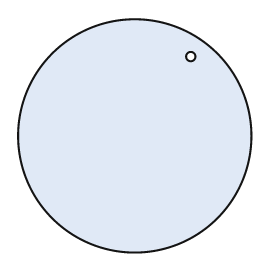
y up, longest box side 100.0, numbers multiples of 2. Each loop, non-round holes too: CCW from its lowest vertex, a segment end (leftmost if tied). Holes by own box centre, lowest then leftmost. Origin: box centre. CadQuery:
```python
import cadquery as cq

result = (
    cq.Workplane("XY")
    .moveTo(0.0, 0.0)
    .circle(50.0)
    .moveTo(24.0, 34.0)
    .circle(2.0)
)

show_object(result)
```